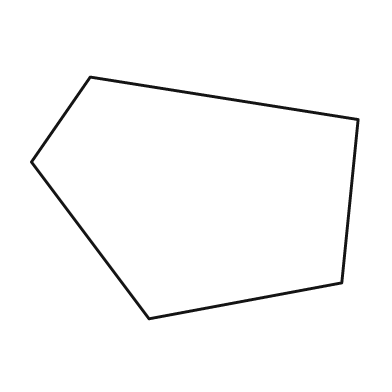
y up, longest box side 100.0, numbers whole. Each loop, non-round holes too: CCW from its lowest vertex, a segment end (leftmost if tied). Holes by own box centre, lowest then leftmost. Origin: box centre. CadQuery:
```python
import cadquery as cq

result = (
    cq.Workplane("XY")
    .moveTo(-14.0, -37.0)
    .lineTo(45.0, -26.0)
    .lineTo(50.0, 24.0)
    .lineTo(-32.0, 37.0)
    .lineTo(-50.0, 11.0)
    .close()
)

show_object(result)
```